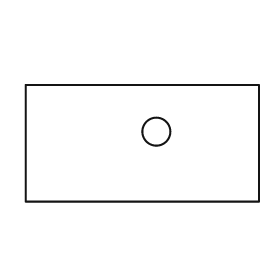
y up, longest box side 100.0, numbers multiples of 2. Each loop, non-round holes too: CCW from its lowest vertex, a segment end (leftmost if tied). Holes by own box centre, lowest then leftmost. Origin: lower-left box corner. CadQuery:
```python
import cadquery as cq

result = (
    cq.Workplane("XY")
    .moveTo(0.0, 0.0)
    .lineTo(100.0, 0.0)
    .lineTo(100.0, 50.0)
    .lineTo(0.0, 50.0)
    .close()
    .moveTo(56.0, 30.0)
    .circle(6.0)
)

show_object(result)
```